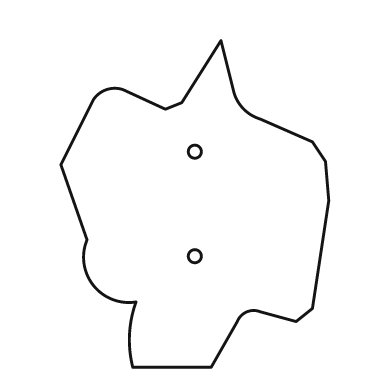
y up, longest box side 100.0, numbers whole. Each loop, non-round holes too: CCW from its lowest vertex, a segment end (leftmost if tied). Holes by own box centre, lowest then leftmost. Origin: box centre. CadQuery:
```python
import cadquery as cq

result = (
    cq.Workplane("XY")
    .moveTo(-19.0, -50.0)
    .lineTo(5.0, -50.0)
    .lineTo(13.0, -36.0)
    .threePointArc((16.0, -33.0), (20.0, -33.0))
    .lineTo(31.0, -36.0)
    .lineTo(36.0, -32.0)
    .lineTo(41.0, 1.0)
    .lineTo(40.0, 13.0)
    .lineTo(36.0, 19.0)
    .lineTo(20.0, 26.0)
    .threePointArc((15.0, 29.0), (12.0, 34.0))
    .lineTo(8.0, 50.0)
    .lineTo(-4.0, 31.0)
    .lineTo(-9.0, 29.0)
    .lineTo(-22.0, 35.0)
    .threePointArc((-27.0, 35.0), (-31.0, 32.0))
    .lineTo(-41.0, 12.0)
    .lineTo(-33.0, -11.0)
    .threePointArc((-31.0, -25.0), (-18.0, -30.0))
    .threePointArc((-20.0, -40.0), (-19.0, -50.0))
    .close()
    .moveTo(0.0, -16.0)
    .circle(2.0)
    .moveTo(0.0, 16.0)
    .circle(2.0)
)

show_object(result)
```